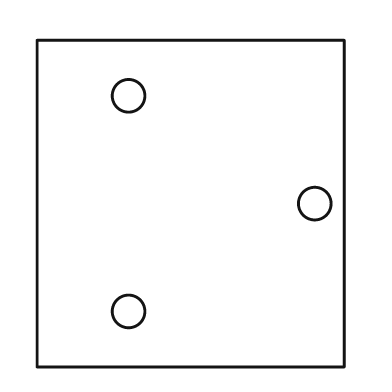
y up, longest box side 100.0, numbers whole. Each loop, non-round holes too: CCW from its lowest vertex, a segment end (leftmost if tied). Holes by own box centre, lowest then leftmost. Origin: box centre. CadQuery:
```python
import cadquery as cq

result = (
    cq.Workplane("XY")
    .moveTo(-47.0, -50.0)
    .lineTo(47.0, -50.0)
    .lineTo(47.0, 50.0)
    .lineTo(-47.0, 50.0)
    .close()
    .moveTo(-19.0, -33.0)
    .circle(5.0)
    .moveTo(38.0, 0.0)
    .circle(5.0)
    .moveTo(-19.0, 33.0)
    .circle(5.0)
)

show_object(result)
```